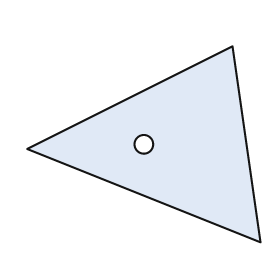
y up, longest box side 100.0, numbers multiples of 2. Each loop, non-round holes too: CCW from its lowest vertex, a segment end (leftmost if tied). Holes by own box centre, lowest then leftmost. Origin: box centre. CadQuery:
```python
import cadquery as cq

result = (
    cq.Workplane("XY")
    .moveTo(50.0, -42.0)
    .lineTo(38.0, 42.0)
    .lineTo(-50.0, -2.0)
    .close()
    .moveTo(0.0, 0.0)
    .circle(4.0)
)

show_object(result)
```